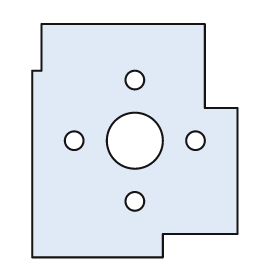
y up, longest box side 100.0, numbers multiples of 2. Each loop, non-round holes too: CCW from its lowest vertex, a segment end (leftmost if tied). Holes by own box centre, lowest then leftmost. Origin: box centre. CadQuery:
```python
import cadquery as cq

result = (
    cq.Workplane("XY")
    .moveTo(-44.0, -50.0)
    .lineTo(12.0, -50.0)
    .lineTo(12.0, -40.0)
    .lineTo(44.0, -40.0)
    .lineTo(44.0, 14.0)
    .lineTo(30.0, 14.0)
    .lineTo(30.0, 50.0)
    .lineTo(-40.0, 50.0)
    .lineTo(-40.0, 30.0)
    .lineTo(-44.0, 30.0)
    .close()
    .moveTo(0.0, -26.0)
    .circle(4.0)
    .moveTo(-26.0, 0.0)
    .circle(4.0)
    .moveTo(0.0, 0.0)
    .circle(12.0)
    .moveTo(26.0, 0.0)
    .circle(4.0)
    .moveTo(0.0, 26.0)
    .circle(4.0)
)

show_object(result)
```